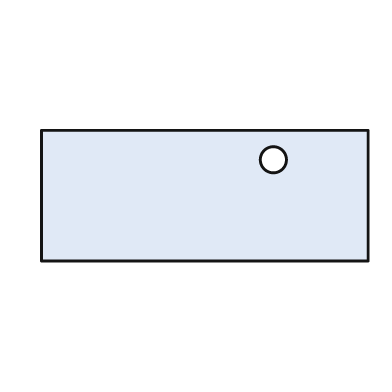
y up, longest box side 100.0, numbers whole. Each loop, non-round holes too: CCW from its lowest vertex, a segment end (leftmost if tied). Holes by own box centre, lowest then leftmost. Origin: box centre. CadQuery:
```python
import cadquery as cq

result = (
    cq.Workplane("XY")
    .moveTo(-50.0, -20.0)
    .lineTo(50.0, -20.0)
    .lineTo(50.0, 20.0)
    .lineTo(-50.0, 20.0)
    .close()
    .moveTo(21.0, 11.0)
    .circle(4.0)
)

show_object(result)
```